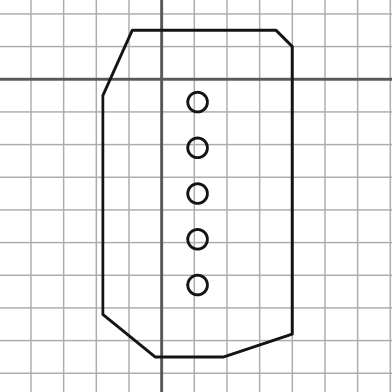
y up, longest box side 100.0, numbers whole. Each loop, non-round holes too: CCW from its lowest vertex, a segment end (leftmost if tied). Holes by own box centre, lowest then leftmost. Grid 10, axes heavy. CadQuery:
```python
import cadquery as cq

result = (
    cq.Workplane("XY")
    .moveTo(-2.0, -85.0)
    .lineTo(19.0, -85.0)
    .lineTo(40.0, -78.0)
    .lineTo(40.0, 10.0)
    .lineTo(35.0, 15.0)
    .lineTo(-9.0, 15.0)
    .lineTo(-18.0, -5.0)
    .lineTo(-18.0, -72.0)
    .close()
    .moveTo(11.0, -63.0)
    .circle(3.0)
    .moveTo(11.0, -49.0)
    .circle(3.0)
    .moveTo(11.0, -35.0)
    .circle(3.0)
    .moveTo(11.0, -21.0)
    .circle(3.0)
    .moveTo(11.0, -7.0)
    .circle(3.0)
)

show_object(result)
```